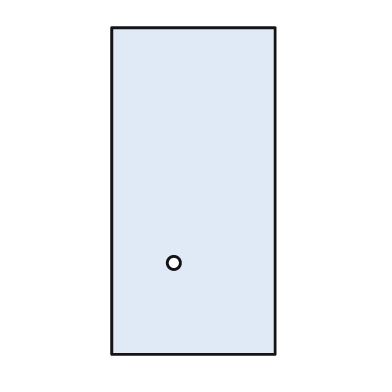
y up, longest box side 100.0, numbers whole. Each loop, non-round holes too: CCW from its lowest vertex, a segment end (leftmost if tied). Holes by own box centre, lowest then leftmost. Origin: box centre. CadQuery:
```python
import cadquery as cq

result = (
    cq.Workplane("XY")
    .moveTo(-25.0, -50.0)
    .lineTo(25.0, -50.0)
    .lineTo(25.0, 50.0)
    .lineTo(-25.0, 50.0)
    .close()
    .moveTo(-6.0, -22.0)
    .circle(2.0)
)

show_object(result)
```